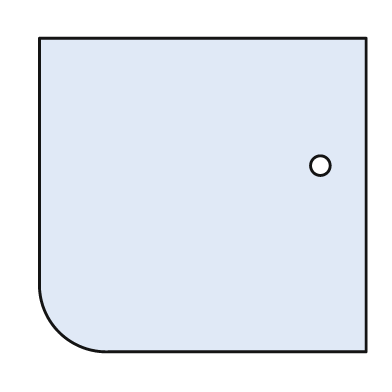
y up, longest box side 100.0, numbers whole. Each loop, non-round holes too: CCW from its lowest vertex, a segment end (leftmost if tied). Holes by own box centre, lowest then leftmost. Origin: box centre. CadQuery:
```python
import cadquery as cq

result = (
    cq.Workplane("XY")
    .moveTo(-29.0, -48.0)
    .lineTo(50.0, -48.0)
    .lineTo(50.0, 48.0)
    .lineTo(-50.0, 48.0)
    .lineTo(-50.0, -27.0)
    .threePointArc((-44.0, -42.0), (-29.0, -48.0))
    .close()
    .moveTo(36.0, 9.0)
    .circle(3.0)
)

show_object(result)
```